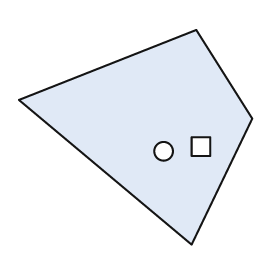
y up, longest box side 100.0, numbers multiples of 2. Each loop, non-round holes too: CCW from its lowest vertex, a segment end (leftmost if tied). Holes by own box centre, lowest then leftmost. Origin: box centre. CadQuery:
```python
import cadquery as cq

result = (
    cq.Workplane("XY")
    .moveTo(24.0, -46.0)
    .lineTo(50.0, 8.0)
    .lineTo(26.0, 46.0)
    .lineTo(-50.0, 16.0)
    .close()
    .moveTo(12.0, -6.0)
    .circle(4.0)
    .moveTo(24.0, -8.0)
    .lineTo(32.0, -8.0)
    .lineTo(32.0, 0.0)
    .lineTo(24.0, 0.0)
    .close()
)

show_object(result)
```